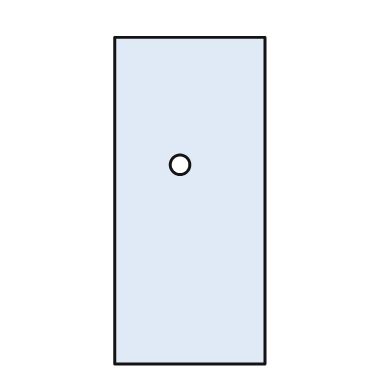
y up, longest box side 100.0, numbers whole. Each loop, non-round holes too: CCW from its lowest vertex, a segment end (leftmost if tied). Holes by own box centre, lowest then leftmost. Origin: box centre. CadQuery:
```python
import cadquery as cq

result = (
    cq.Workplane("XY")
    .moveTo(-23.0, -50.0)
    .lineTo(23.0, -50.0)
    .lineTo(23.0, 50.0)
    .lineTo(-23.0, 50.0)
    .close()
    .moveTo(-3.0, 11.0)
    .circle(3.0)
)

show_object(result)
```